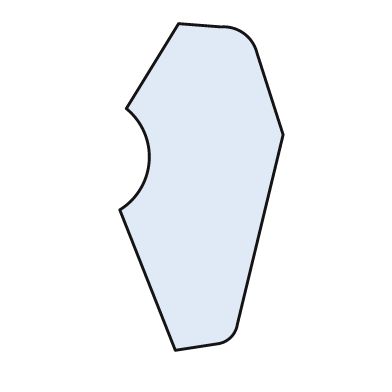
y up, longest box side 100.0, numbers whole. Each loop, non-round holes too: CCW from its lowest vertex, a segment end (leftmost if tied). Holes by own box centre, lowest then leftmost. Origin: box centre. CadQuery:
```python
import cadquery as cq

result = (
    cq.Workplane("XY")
    .moveTo(-8.0, -50.0)
    .lineTo(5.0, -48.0)
    .threePointArc((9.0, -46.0), (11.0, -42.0))
    .lineTo(25.0, 16.0)
    .lineTo(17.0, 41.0)
    .threePointArc((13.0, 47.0), (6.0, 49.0))
    .lineTo(-7.0, 50.0)
    .lineTo(-23.0, 24.0)
    .threePointArc((-16.0, 8.0), (-25.0, -7.0))
    .close()
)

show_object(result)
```